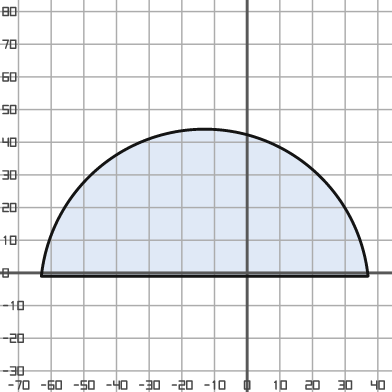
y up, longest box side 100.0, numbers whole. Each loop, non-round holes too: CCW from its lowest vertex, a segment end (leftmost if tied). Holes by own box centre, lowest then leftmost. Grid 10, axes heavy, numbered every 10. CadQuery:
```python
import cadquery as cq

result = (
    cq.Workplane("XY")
    .moveTo(-63.0, -1.0)
    .lineTo(37.0, -1.0)
    .threePointArc((-13.0, 44.0), (-63.0, -1.0))
    .close()
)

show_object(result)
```